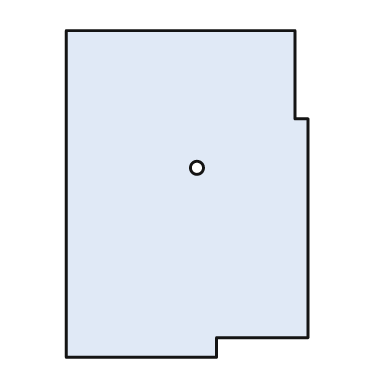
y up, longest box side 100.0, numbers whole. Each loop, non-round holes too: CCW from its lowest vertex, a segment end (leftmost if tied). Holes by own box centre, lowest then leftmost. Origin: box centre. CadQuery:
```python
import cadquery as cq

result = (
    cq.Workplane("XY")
    .moveTo(-37.0, -50.0)
    .lineTo(9.0, -50.0)
    .lineTo(9.0, -44.0)
    .lineTo(37.0, -44.0)
    .lineTo(37.0, 23.0)
    .lineTo(33.0, 23.0)
    .lineTo(33.0, 50.0)
    .lineTo(-37.0, 50.0)
    .close()
    .moveTo(3.0, 8.0)
    .circle(2.0)
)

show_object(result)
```